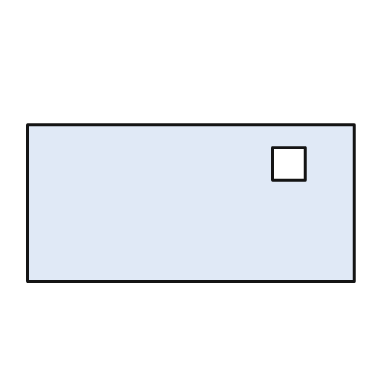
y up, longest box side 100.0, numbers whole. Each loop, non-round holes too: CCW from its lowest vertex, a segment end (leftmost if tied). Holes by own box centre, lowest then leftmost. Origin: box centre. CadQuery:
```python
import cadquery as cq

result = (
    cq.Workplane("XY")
    .moveTo(-50.0, -24.0)
    .lineTo(50.0, -24.0)
    .lineTo(50.0, 24.0)
    .lineTo(-50.0, 24.0)
    .close()
    .moveTo(25.0, 7.0)
    .lineTo(35.0, 7.0)
    .lineTo(35.0, 17.0)
    .lineTo(25.0, 17.0)
    .close()
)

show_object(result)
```